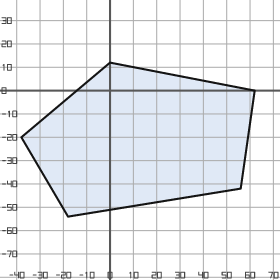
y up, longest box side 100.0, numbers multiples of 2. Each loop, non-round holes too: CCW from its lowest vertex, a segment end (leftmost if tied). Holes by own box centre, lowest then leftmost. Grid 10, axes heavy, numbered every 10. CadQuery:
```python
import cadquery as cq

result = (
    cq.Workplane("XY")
    .moveTo(-18.0, -54.0)
    .lineTo(56.0, -42.0)
    .lineTo(62.0, 0.0)
    .lineTo(0.0, 12.0)
    .lineTo(-38.0, -20.0)
    .close()
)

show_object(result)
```